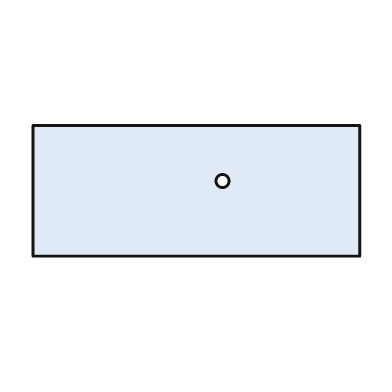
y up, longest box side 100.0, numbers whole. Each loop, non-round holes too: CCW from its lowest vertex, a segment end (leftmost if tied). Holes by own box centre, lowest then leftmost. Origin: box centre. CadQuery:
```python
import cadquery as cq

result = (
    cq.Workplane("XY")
    .moveTo(-50.0, -20.0)
    .lineTo(50.0, -20.0)
    .lineTo(50.0, 20.0)
    .lineTo(-50.0, 20.0)
    .close()
    .moveTo(8.0, 3.0)
    .circle(2.0)
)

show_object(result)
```